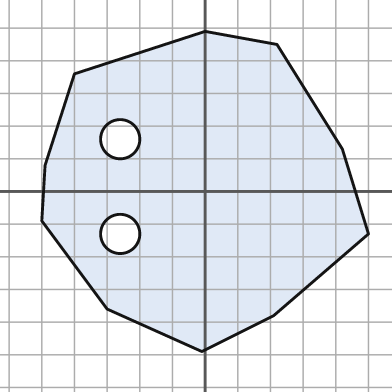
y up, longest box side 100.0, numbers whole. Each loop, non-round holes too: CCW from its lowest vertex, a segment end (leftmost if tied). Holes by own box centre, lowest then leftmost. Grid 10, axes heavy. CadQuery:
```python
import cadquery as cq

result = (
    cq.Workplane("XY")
    .moveTo(-1.0, -49.0)
    .lineTo(21.0, -38.0)
    .lineTo(50.0, -13.0)
    .lineTo(42.0, 13.0)
    .lineTo(22.0, 45.0)
    .lineTo(0.0, 49.0)
    .lineTo(-40.0, 36.0)
    .lineTo(-49.0, 8.0)
    .lineTo(-50.0, -9.0)
    .lineTo(-30.0, -36.0)
    .close()
    .moveTo(-26.0, -13.0)
    .circle(6.0)
    .moveTo(-26.0, 16.0)
    .circle(6.0)
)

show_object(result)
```